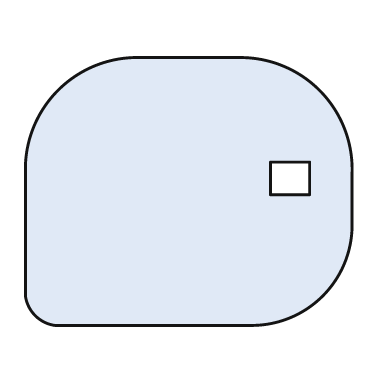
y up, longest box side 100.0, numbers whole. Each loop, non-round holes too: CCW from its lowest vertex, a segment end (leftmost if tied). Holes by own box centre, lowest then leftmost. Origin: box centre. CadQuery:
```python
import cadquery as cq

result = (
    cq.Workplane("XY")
    .moveTo(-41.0, -41.0)
    .lineTo(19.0, -41.0)
    .threePointArc((41.0, -32.0), (50.0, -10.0))
    .lineTo(50.0, 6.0)
    .threePointArc((40.0, 31.0), (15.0, 41.0))
    .lineTo(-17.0, 41.0)
    .threePointArc((-40.0, 31.0), (-50.0, 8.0))
    .lineTo(-50.0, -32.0)
    .threePointArc((-47.0, -38.0), (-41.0, -41.0))
    .close()
    .moveTo(25.0, -1.0)
    .lineTo(37.0, -1.0)
    .lineTo(37.0, 9.0)
    .lineTo(25.0, 9.0)
    .close()
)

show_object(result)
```